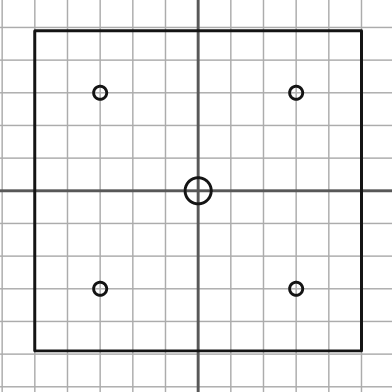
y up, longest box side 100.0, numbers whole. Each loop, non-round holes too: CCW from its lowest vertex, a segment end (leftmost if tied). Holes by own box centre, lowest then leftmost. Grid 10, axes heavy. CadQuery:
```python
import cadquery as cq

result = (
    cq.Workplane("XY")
    .moveTo(-50.0, -49.0)
    .lineTo(50.0, -49.0)
    .lineTo(50.0, 49.0)
    .lineTo(-50.0, 49.0)
    .close()
    .moveTo(-30.0, -30.0)
    .circle(2.0)
    .moveTo(30.0, -30.0)
    .circle(2.0)
    .moveTo(0.0, 0.0)
    .circle(4.0)
    .moveTo(-30.0, 30.0)
    .circle(2.0)
    .moveTo(30.0, 30.0)
    .circle(2.0)
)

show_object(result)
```